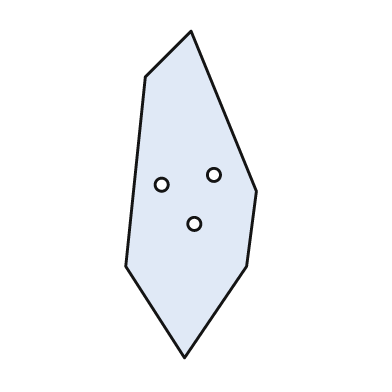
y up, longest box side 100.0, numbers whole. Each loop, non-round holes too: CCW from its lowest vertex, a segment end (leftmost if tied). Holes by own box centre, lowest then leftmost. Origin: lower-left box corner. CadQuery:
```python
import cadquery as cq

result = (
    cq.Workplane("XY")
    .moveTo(18.0, 0.0)
    .lineTo(37.0, 28.0)
    .lineTo(40.0, 51.0)
    .lineTo(20.0, 100.0)
    .lineTo(6.0, 86.0)
    .lineTo(0.0, 28.0)
    .close()
    .moveTo(21.0, 41.0)
    .circle(2.0)
    .moveTo(11.0, 53.0)
    .circle(2.0)
    .moveTo(27.0, 56.0)
    .circle(2.0)
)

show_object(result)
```